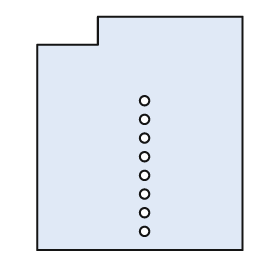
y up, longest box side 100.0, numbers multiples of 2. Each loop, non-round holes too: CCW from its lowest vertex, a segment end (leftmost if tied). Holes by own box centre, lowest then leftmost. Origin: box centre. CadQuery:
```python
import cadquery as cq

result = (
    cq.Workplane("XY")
    .moveTo(-44.0, -50.0)
    .lineTo(44.0, -50.0)
    .lineTo(44.0, 50.0)
    .lineTo(-18.0, 50.0)
    .lineTo(-18.0, 38.0)
    .lineTo(-44.0, 38.0)
    .close()
    .moveTo(2.0, -42.0)
    .circle(2.0)
    .moveTo(2.0, -34.0)
    .circle(2.0)
    .moveTo(2.0, -26.0)
    .circle(2.0)
    .moveTo(2.0, -18.0)
    .circle(2.0)
    .moveTo(2.0, -10.0)
    .circle(2.0)
    .moveTo(2.0, -2.0)
    .circle(2.0)
    .moveTo(2.0, 6.0)
    .circle(2.0)
    .moveTo(2.0, 14.0)
    .circle(2.0)
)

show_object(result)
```